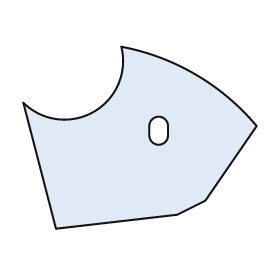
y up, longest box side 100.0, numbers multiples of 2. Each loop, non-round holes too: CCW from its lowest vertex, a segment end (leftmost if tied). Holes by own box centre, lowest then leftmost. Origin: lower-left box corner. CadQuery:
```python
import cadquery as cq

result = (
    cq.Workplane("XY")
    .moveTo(14.0, 0.0)
    .lineTo(66.0, 6.0)
    .lineTo(78.0, 12.0)
    .lineTo(100.0, 44.0)
    .threePointArc((74.0, 66.0), (42.0, 78.0))
    .threePointArc((30.0, 50.0), (0.0, 54.0))
    .close()
    .moveTo(54.0, 40.0)
    .threePointArc((58.0, 36.0), (62.0, 40.0))
    .lineTo(62.0, 44.0)
    .threePointArc((58.0, 48.0), (54.0, 44.0))
    .close()
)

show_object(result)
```